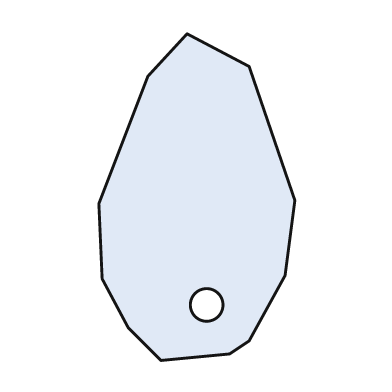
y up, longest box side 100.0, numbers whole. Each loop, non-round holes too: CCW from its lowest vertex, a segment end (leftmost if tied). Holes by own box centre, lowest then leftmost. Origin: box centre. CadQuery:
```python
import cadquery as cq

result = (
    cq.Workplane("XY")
    .moveTo(-11.0, -50.0)
    .lineTo(10.0, -48.0)
    .lineTo(16.0, -44.0)
    .lineTo(27.0, -24.0)
    .lineTo(30.0, -1.0)
    .lineTo(16.0, 40.0)
    .lineTo(-3.0, 50.0)
    .lineTo(-15.0, 37.0)
    .lineTo(-30.0, -2.0)
    .lineTo(-29.0, -25.0)
    .lineTo(-21.0, -40.0)
    .close()
    .moveTo(3.0, -33.0)
    .circle(5.0)
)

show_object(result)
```